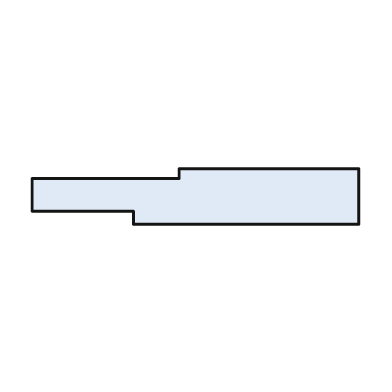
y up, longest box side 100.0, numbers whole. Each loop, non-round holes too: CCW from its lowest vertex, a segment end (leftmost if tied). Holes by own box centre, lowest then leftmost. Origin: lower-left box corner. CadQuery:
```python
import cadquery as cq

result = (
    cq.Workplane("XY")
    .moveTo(31.0, 0.0)
    .lineTo(100.0, 0.0)
    .lineTo(100.0, 17.0)
    .lineTo(45.0, 17.0)
    .lineTo(45.0, 14.0)
    .lineTo(0.0, 14.0)
    .lineTo(0.0, 4.0)
    .lineTo(31.0, 4.0)
    .close()
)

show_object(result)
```